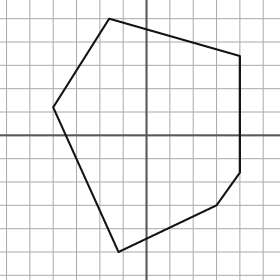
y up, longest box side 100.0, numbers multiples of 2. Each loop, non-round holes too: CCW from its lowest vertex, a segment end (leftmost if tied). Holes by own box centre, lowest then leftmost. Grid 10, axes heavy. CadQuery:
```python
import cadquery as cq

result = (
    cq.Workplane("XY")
    .moveTo(-12.0, -50.0)
    .lineTo(30.0, -30.0)
    .lineTo(40.0, -16.0)
    .lineTo(40.0, 34.0)
    .lineTo(-16.0, 50.0)
    .lineTo(-40.0, 12.0)
    .close()
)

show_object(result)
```